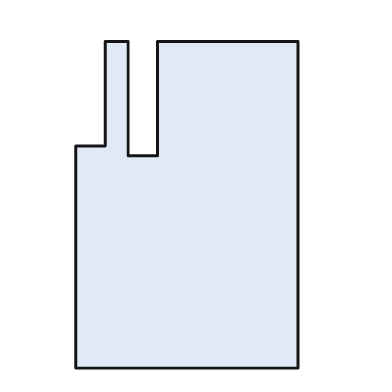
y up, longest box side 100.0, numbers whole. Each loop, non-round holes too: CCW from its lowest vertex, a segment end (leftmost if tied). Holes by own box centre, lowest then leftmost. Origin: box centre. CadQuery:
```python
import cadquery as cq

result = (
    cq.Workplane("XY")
    .moveTo(-34.0, -50.0)
    .lineTo(34.0, -50.0)
    .lineTo(34.0, 50.0)
    .lineTo(-9.0, 50.0)
    .lineTo(-9.0, 15.0)
    .lineTo(-18.0, 15.0)
    .lineTo(-18.0, 50.0)
    .lineTo(-25.0, 50.0)
    .lineTo(-25.0, 18.0)
    .lineTo(-34.0, 18.0)
    .close()
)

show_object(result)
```